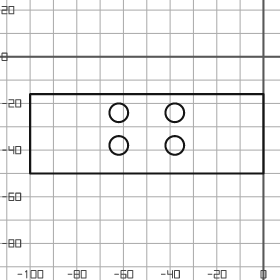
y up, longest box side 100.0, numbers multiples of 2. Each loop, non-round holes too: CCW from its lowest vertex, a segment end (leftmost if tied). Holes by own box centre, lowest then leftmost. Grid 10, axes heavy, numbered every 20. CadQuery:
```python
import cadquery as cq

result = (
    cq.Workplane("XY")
    .moveTo(-100.0, -50.0)
    .lineTo(0.0, -50.0)
    .lineTo(0.0, -16.0)
    .lineTo(-100.0, -16.0)
    .close()
    .moveTo(-62.0, -38.0)
    .circle(4.0)
    .moveTo(-38.0, -38.0)
    .circle(4.0)
    .moveTo(-62.0, -24.0)
    .circle(4.0)
    .moveTo(-38.0, -24.0)
    .circle(4.0)
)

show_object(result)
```